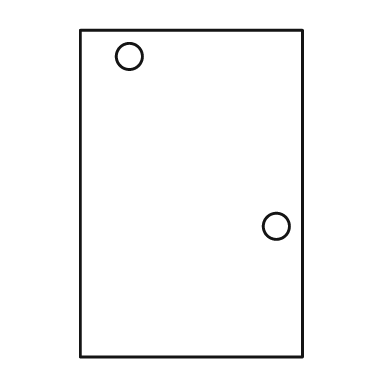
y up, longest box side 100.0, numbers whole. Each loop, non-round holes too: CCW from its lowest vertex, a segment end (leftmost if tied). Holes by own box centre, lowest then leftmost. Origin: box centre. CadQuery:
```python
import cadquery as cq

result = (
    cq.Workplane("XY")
    .moveTo(-34.0, -50.0)
    .lineTo(34.0, -50.0)
    .lineTo(34.0, 50.0)
    .lineTo(-34.0, 50.0)
    .close()
    .moveTo(26.0, -10.0)
    .circle(4.0)
    .moveTo(-19.0, 42.0)
    .circle(4.0)
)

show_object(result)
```